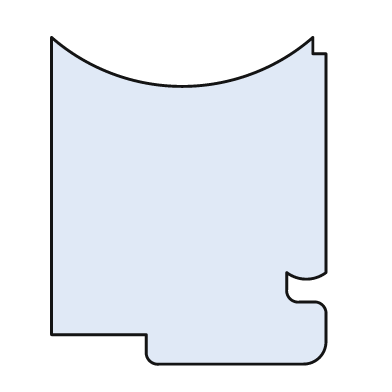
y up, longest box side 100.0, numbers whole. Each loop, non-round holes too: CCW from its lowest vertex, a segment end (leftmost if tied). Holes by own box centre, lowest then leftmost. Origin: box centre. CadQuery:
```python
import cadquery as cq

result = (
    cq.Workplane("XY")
    .moveTo(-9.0, -50.0)
    .lineTo(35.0, -50.0)
    .threePointArc((40.0, -48.0), (42.0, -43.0))
    .lineTo(42.0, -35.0)
    .threePointArc((41.0, -32.0), (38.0, -31.0))
    .lineTo(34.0, -31.0)
    .threePointArc((31.0, -30.0), (30.0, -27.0))
    .lineTo(30.0, -22.0)
    .threePointArc((36.0, -24.0), (42.0, -22.0))
    .lineTo(42.0, 45.0)
    .lineTo(38.0, 45.0)
    .lineTo(38.0, 50.0)
    .threePointArc((-2.0, 35.0), (-42.0, 50.0))
    .lineTo(-42.0, -41.0)
    .lineTo(-13.0, -41.0)
    .lineTo(-13.0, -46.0)
    .threePointArc((-12.0, -49.0), (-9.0, -50.0))
    .close()
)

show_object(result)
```